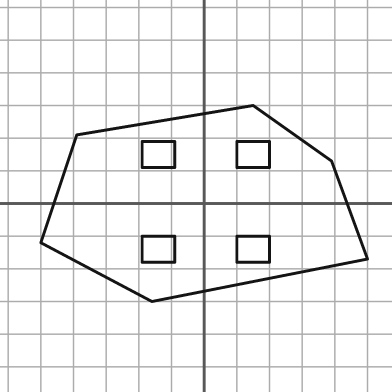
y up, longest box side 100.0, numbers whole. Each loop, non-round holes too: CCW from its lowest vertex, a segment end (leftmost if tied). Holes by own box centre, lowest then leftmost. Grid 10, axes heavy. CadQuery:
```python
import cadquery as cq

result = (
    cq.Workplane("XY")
    .moveTo(-16.0, -30.0)
    .lineTo(50.0, -17.0)
    .lineTo(39.0, 13.0)
    .lineTo(15.0, 30.0)
    .lineTo(-39.0, 21.0)
    .lineTo(-50.0, -12.0)
    .close()
    .moveTo(-19.0, -18.0)
    .lineTo(-9.0, -18.0)
    .lineTo(-9.0, -10.0)
    .lineTo(-19.0, -10.0)
    .close()
    .moveTo(10.0, -18.0)
    .lineTo(20.0, -18.0)
    .lineTo(20.0, -10.0)
    .lineTo(10.0, -10.0)
    .close()
    .moveTo(-19.0, 11.0)
    .lineTo(-9.0, 11.0)
    .lineTo(-9.0, 19.0)
    .lineTo(-19.0, 19.0)
    .close()
    .moveTo(10.0, 11.0)
    .lineTo(20.0, 11.0)
    .lineTo(20.0, 19.0)
    .lineTo(10.0, 19.0)
    .close()
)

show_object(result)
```